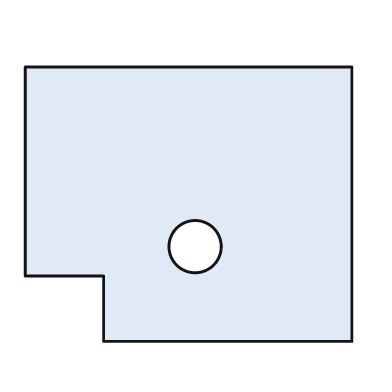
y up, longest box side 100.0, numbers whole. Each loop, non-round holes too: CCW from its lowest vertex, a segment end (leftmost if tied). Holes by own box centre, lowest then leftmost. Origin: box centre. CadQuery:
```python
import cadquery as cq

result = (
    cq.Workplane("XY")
    .moveTo(-26.0, -42.0)
    .lineTo(50.0, -42.0)
    .lineTo(50.0, 42.0)
    .lineTo(-50.0, 42.0)
    .lineTo(-50.0, -22.0)
    .lineTo(-26.0, -22.0)
    .close()
    .moveTo(2.0, -13.0)
    .circle(8.0)
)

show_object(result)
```